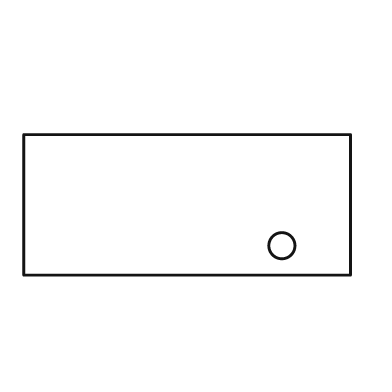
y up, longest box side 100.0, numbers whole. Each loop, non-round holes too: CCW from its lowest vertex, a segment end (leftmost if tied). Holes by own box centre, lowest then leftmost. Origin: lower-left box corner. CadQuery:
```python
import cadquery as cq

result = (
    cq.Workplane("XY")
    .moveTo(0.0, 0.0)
    .lineTo(100.0, 0.0)
    .lineTo(100.0, 43.0)
    .lineTo(0.0, 43.0)
    .close()
    .moveTo(79.0, 9.0)
    .circle(4.0)
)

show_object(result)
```